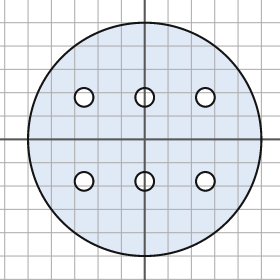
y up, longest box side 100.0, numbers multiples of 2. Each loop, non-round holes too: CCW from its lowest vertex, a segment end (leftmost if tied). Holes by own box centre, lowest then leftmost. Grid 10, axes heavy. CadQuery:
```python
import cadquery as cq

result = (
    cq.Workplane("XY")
    .moveTo(0.0, 0.0)
    .circle(50.0)
    .moveTo(-26.0, -18.0)
    .circle(4.0)
    .moveTo(0.0, -18.0)
    .circle(4.0)
    .moveTo(26.0, -18.0)
    .circle(4.0)
    .moveTo(-26.0, 18.0)
    .circle(4.0)
    .moveTo(0.0, 18.0)
    .circle(4.0)
    .moveTo(26.0, 18.0)
    .circle(4.0)
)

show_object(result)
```